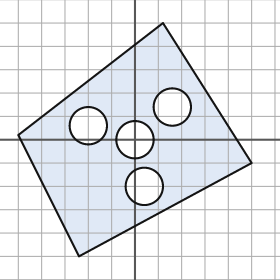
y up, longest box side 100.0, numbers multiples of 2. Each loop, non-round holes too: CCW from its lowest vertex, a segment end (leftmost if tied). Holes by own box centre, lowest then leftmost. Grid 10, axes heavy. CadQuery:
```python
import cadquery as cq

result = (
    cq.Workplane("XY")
    .moveTo(-24.0, -50.0)
    .lineTo(50.0, -10.0)
    .lineTo(12.0, 50.0)
    .lineTo(-50.0, 2.0)
    .close()
    .moveTo(4.0, -20.0)
    .circle(8.0)
    .moveTo(0.0, 0.0)
    .circle(8.0)
    .moveTo(-20.0, 6.0)
    .circle(8.0)
    .moveTo(16.0, 14.0)
    .circle(8.0)
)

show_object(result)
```